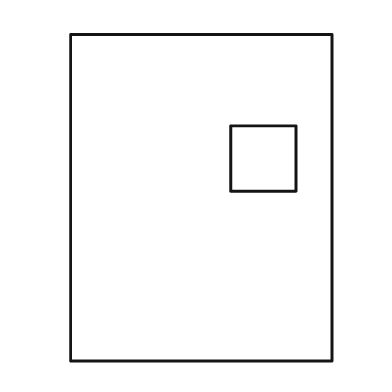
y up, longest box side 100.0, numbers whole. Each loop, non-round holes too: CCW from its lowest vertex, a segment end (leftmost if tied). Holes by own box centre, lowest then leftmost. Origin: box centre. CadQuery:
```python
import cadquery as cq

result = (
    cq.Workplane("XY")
    .moveTo(-40.0, -50.0)
    .lineTo(40.0, -50.0)
    .lineTo(40.0, 50.0)
    .lineTo(-40.0, 50.0)
    .close()
    .moveTo(9.0, 2.0)
    .lineTo(29.0, 2.0)
    .lineTo(29.0, 22.0)
    .lineTo(9.0, 22.0)
    .close()
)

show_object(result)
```